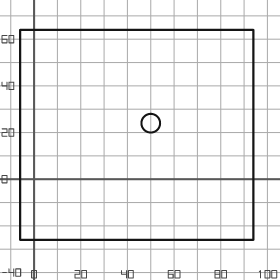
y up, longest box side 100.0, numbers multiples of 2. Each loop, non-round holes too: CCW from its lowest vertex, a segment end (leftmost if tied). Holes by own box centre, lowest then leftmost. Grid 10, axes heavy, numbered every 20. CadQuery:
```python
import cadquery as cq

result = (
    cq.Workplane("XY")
    .moveTo(-6.0, -26.0)
    .lineTo(94.0, -26.0)
    .lineTo(94.0, 64.0)
    .lineTo(-6.0, 64.0)
    .close()
    .moveTo(50.0, 24.0)
    .circle(4.0)
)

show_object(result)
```